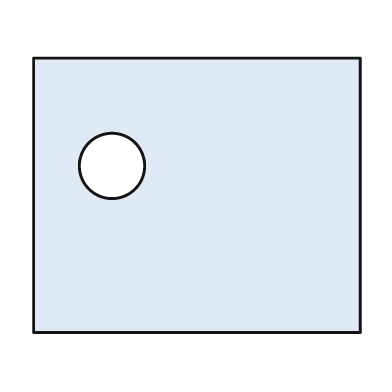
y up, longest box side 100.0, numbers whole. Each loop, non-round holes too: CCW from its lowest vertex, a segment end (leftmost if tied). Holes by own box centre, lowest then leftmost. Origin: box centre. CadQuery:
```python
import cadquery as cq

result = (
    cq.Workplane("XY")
    .moveTo(-50.0, -42.0)
    .lineTo(50.0, -42.0)
    .lineTo(50.0, 42.0)
    .lineTo(-50.0, 42.0)
    .close()
    .moveTo(-26.0, 9.0)
    .circle(10.0)
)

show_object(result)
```